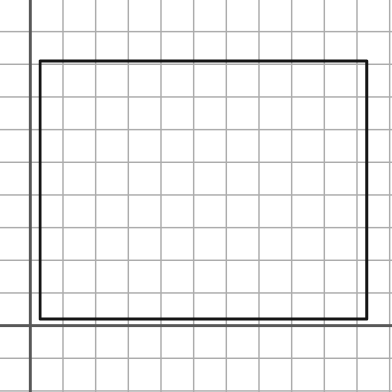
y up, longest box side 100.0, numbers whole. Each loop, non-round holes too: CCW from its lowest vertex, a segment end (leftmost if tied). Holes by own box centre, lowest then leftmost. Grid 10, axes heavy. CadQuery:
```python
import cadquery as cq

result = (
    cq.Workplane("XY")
    .moveTo(3.0, 2.0)
    .lineTo(103.0, 2.0)
    .lineTo(103.0, 81.0)
    .lineTo(3.0, 81.0)
    .close()
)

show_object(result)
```